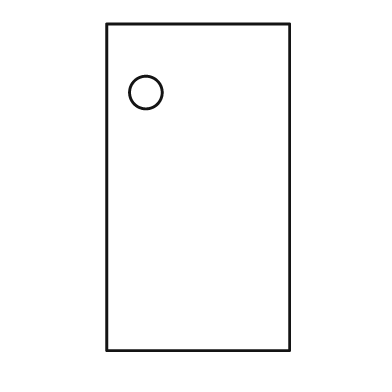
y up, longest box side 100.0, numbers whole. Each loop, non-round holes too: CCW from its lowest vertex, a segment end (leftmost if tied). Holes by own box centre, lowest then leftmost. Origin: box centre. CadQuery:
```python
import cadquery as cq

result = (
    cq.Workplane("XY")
    .moveTo(-28.0, -50.0)
    .lineTo(28.0, -50.0)
    .lineTo(28.0, 50.0)
    .lineTo(-28.0, 50.0)
    .close()
    .moveTo(-16.0, 29.0)
    .circle(5.0)
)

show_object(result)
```